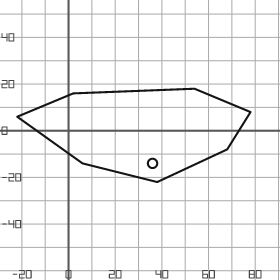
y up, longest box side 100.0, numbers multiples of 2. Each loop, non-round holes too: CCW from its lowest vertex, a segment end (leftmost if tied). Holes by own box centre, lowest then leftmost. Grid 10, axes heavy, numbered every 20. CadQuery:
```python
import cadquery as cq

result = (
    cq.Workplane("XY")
    .moveTo(38.0, -22.0)
    .lineTo(68.0, -8.0)
    .lineTo(78.0, 8.0)
    .lineTo(54.0, 18.0)
    .lineTo(2.0, 16.0)
    .lineTo(-22.0, 6.0)
    .lineTo(6.0, -14.0)
    .close()
    .moveTo(36.0, -14.0)
    .circle(2.0)
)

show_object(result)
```